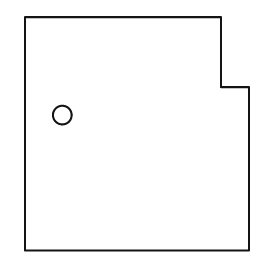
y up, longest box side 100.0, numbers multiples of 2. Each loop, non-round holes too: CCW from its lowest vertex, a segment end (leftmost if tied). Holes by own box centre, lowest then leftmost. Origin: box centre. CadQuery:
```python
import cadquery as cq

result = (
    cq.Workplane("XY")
    .moveTo(-48.0, -50.0)
    .lineTo(48.0, -50.0)
    .lineTo(48.0, 20.0)
    .lineTo(36.0, 20.0)
    .lineTo(36.0, 50.0)
    .lineTo(-48.0, 50.0)
    .close()
    .moveTo(-32.0, 8.0)
    .circle(4.0)
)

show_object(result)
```